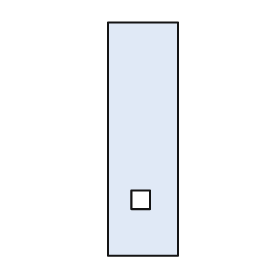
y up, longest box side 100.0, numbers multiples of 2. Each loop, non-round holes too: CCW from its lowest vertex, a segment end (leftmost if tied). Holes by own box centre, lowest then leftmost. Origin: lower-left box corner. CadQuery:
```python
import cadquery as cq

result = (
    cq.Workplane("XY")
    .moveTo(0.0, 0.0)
    .lineTo(30.0, 0.0)
    .lineTo(30.0, 100.0)
    .lineTo(0.0, 100.0)
    .close()
    .moveTo(10.0, 20.0)
    .lineTo(18.0, 20.0)
    .lineTo(18.0, 28.0)
    .lineTo(10.0, 28.0)
    .close()
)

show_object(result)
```